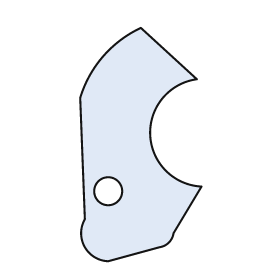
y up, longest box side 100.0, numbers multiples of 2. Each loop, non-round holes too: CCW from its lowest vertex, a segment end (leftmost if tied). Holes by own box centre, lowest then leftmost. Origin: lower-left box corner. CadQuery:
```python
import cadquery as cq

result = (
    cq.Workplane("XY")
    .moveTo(12.0, 0.0)
    .lineTo(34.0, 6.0)
    .threePointArc((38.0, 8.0), (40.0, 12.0))
    .lineTo(52.0, 32.0)
    .threePointArc((30.0, 54.0), (50.0, 78.0))
    .lineTo(26.0, 100.0)
    .threePointArc((10.0, 88.0), (0.0, 70.0))
    .lineTo(2.0, 18.0)
    .threePointArc((2.0, 6.0), (12.0, 0.0))
    .close()
    .moveTo(12.0, 30.0)
    .circle(6.0)
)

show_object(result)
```